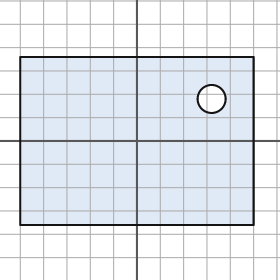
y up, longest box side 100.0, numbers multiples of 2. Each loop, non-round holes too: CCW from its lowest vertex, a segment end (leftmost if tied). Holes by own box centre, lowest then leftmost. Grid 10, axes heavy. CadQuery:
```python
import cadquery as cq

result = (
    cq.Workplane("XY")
    .moveTo(-50.0, -36.0)
    .lineTo(50.0, -36.0)
    .lineTo(50.0, 36.0)
    .lineTo(-50.0, 36.0)
    .close()
    .moveTo(32.0, 18.0)
    .circle(6.0)
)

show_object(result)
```